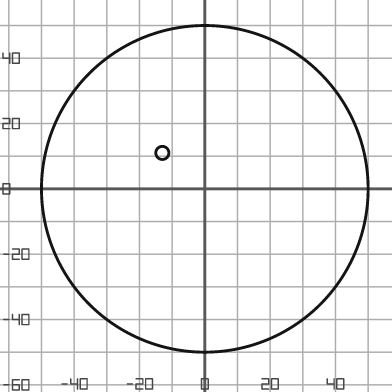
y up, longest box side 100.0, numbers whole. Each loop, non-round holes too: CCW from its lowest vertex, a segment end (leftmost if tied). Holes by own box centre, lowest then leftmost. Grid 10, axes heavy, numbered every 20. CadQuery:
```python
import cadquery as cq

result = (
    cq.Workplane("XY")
    .moveTo(0.0, 0.0)
    .circle(50.0)
    .moveTo(-13.0, 11.0)
    .circle(2.0)
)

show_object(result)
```